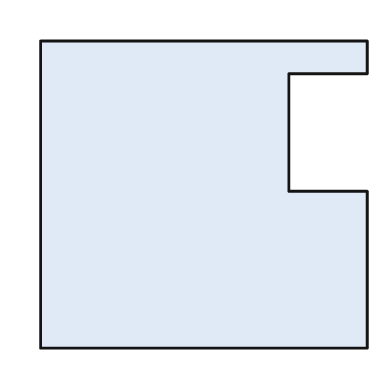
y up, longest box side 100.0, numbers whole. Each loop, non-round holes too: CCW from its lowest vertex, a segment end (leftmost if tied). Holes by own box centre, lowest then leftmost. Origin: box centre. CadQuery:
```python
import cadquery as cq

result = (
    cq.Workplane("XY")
    .moveTo(-50.0, -47.0)
    .lineTo(50.0, -47.0)
    .lineTo(50.0, 1.0)
    .lineTo(26.0, 1.0)
    .lineTo(26.0, 37.0)
    .lineTo(50.0, 37.0)
    .lineTo(50.0, 47.0)
    .lineTo(-50.0, 47.0)
    .close()
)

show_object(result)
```